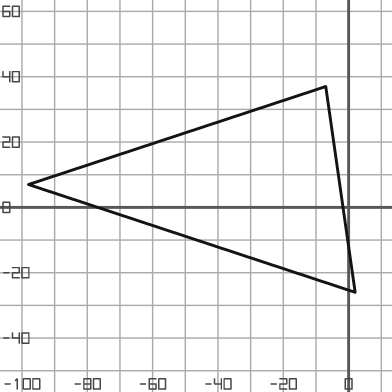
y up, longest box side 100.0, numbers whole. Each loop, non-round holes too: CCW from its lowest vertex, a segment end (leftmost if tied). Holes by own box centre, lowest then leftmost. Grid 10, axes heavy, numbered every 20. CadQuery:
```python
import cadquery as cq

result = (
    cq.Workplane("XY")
    .moveTo(2.0, -26.0)
    .lineTo(-7.0, 37.0)
    .lineTo(-98.0, 7.0)
    .close()
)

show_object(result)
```